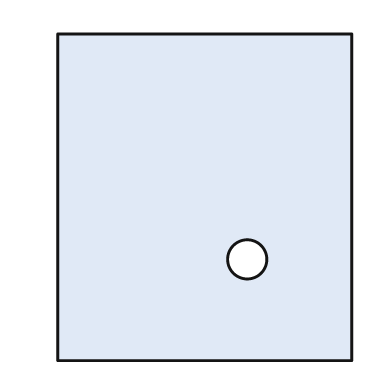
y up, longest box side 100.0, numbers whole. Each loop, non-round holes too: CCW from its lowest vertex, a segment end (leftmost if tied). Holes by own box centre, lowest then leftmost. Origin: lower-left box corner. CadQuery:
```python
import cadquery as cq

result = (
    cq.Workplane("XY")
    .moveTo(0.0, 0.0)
    .lineTo(90.0, 0.0)
    .lineTo(90.0, 100.0)
    .lineTo(0.0, 100.0)
    .close()
    .moveTo(58.0, 31.0)
    .circle(6.0)
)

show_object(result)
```